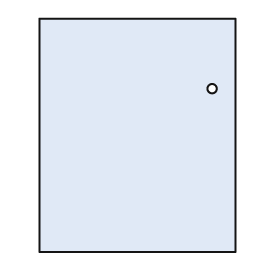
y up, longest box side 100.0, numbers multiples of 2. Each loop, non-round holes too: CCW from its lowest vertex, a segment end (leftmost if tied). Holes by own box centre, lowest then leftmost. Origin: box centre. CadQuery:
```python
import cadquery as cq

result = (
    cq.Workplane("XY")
    .moveTo(-42.0, -50.0)
    .lineTo(42.0, -50.0)
    .lineTo(42.0, 50.0)
    .lineTo(-42.0, 50.0)
    .close()
    .moveTo(32.0, 20.0)
    .circle(2.0)
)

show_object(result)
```